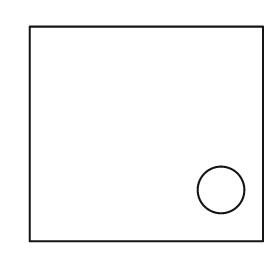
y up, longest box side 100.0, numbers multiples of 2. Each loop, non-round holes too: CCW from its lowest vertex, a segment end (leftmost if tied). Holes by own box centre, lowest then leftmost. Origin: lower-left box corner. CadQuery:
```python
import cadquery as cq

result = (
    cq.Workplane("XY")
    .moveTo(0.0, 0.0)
    .lineTo(100.0, 0.0)
    .lineTo(100.0, 92.0)
    .lineTo(0.0, 92.0)
    .close()
    .moveTo(82.0, 22.0)
    .circle(10.0)
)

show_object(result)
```